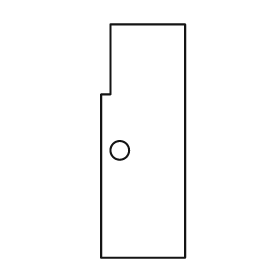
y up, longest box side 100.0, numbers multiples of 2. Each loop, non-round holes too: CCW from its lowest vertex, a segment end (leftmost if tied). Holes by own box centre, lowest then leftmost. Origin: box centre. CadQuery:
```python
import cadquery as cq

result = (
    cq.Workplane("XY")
    .moveTo(-18.0, -50.0)
    .lineTo(18.0, -50.0)
    .lineTo(18.0, 50.0)
    .lineTo(-14.0, 50.0)
    .lineTo(-14.0, 20.0)
    .lineTo(-18.0, 20.0)
    .close()
    .moveTo(-10.0, -4.0)
    .circle(4.0)
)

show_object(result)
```